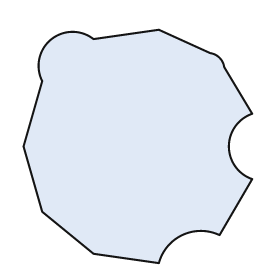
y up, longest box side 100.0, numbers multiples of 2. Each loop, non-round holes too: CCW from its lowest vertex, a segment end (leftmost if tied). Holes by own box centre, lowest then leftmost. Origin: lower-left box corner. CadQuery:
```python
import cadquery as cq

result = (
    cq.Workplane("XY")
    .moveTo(58.0, 0.0)
    .threePointArc((68.0, 12.0), (84.0, 12.0))
    .lineTo(98.0, 36.0)
    .threePointArc((88.0, 50.0), (98.0, 64.0))
    .lineTo(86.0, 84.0)
    .threePointArc((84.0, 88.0), (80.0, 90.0))
    .lineTo(58.0, 100.0)
    .lineTo(30.0, 96.0)
    .threePointArc((12.0, 96.0), (8.0, 78.0))
    .lineTo(0.0, 50.0)
    .lineTo(8.0, 22.0)
    .lineTo(30.0, 4.0)
    .close()
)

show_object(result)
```